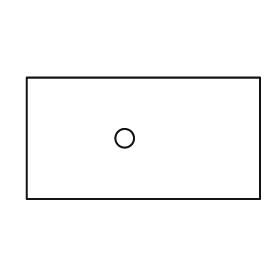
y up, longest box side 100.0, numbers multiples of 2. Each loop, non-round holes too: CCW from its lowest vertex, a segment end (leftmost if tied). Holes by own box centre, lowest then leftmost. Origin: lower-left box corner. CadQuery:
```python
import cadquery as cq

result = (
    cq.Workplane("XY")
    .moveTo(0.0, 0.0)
    .lineTo(100.0, 0.0)
    .lineTo(100.0, 52.0)
    .lineTo(0.0, 52.0)
    .close()
    .moveTo(42.0, 26.0)
    .circle(4.0)
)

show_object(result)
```